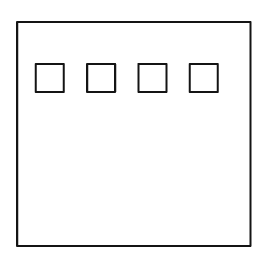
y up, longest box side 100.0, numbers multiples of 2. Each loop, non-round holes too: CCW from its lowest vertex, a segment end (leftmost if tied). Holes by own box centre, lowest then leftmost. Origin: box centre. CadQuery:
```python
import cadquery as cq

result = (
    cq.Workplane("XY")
    .moveTo(-50.0, -48.0)
    .lineTo(50.0, -48.0)
    .lineTo(50.0, 48.0)
    .lineTo(-50.0, 48.0)
    .close()
    .moveTo(-42.0, 18.0)
    .lineTo(-30.0, 18.0)
    .lineTo(-30.0, 30.0)
    .lineTo(-42.0, 30.0)
    .close()
    .moveTo(-20.0, 18.0)
    .lineTo(-8.0, 18.0)
    .lineTo(-8.0, 30.0)
    .lineTo(-20.0, 30.0)
    .close()
    .moveTo(2.0, 18.0)
    .lineTo(14.0, 18.0)
    .lineTo(14.0, 30.0)
    .lineTo(2.0, 30.0)
    .close()
    .moveTo(24.0, 18.0)
    .lineTo(36.0, 18.0)
    .lineTo(36.0, 30.0)
    .lineTo(24.0, 30.0)
    .close()
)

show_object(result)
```